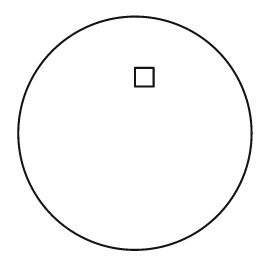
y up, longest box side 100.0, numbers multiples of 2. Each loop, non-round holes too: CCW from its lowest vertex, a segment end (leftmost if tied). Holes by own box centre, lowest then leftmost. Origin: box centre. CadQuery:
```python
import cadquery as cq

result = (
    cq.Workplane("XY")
    .moveTo(0.0, 0.0)
    .circle(50.0)
    .moveTo(0.0, 20.0)
    .lineTo(8.0, 20.0)
    .lineTo(8.0, 28.0)
    .lineTo(0.0, 28.0)
    .close()
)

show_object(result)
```